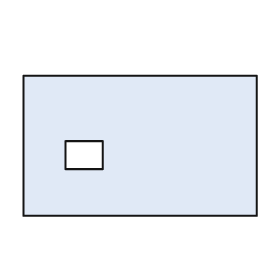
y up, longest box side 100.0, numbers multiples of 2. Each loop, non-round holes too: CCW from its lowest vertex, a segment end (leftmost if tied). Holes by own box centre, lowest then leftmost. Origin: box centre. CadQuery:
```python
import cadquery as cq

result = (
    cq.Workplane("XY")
    .moveTo(-50.0, -30.0)
    .lineTo(50.0, -30.0)
    .lineTo(50.0, 30.0)
    .lineTo(-50.0, 30.0)
    .close()
    .moveTo(-32.0, -10.0)
    .lineTo(-16.0, -10.0)
    .lineTo(-16.0, 2.0)
    .lineTo(-32.0, 2.0)
    .close()
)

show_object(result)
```